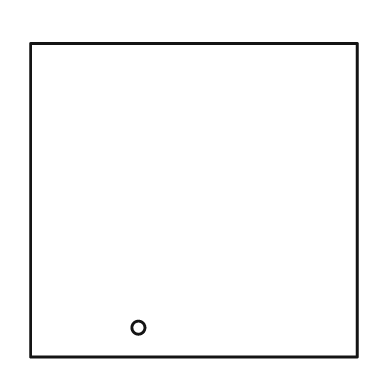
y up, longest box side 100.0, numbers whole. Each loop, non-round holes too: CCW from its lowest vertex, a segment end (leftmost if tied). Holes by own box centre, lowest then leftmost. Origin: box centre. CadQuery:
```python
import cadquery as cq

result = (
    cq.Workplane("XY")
    .moveTo(-50.0, -48.0)
    .lineTo(50.0, -48.0)
    .lineTo(50.0, 48.0)
    .lineTo(-50.0, 48.0)
    .close()
    .moveTo(-17.0, -39.0)
    .circle(2.0)
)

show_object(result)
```